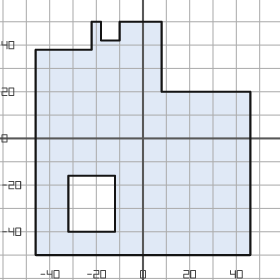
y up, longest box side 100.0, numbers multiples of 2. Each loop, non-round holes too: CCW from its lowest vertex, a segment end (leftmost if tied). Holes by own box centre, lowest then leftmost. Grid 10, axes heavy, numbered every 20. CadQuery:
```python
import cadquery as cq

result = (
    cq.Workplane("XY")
    .moveTo(-46.0, -50.0)
    .lineTo(46.0, -50.0)
    .lineTo(46.0, 20.0)
    .lineTo(8.0, 20.0)
    .lineTo(8.0, 50.0)
    .lineTo(-10.0, 50.0)
    .lineTo(-10.0, 42.0)
    .lineTo(-18.0, 42.0)
    .lineTo(-18.0, 50.0)
    .lineTo(-22.0, 50.0)
    .lineTo(-22.0, 38.0)
    .lineTo(-46.0, 38.0)
    .close()
    .moveTo(-32.0, -40.0)
    .lineTo(-12.0, -40.0)
    .lineTo(-12.0, -16.0)
    .lineTo(-32.0, -16.0)
    .close()
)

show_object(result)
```